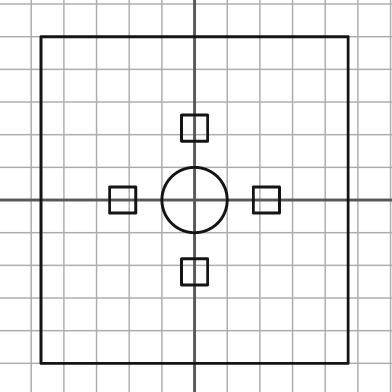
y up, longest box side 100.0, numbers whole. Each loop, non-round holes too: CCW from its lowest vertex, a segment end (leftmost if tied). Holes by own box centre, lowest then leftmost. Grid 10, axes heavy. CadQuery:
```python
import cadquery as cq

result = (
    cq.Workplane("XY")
    .moveTo(-47.0, -50.0)
    .lineTo(47.0, -50.0)
    .lineTo(47.0, 50.0)
    .lineTo(-47.0, 50.0)
    .close()
    .moveTo(-4.0, -26.0)
    .lineTo(4.0, -26.0)
    .lineTo(4.0, -18.0)
    .lineTo(-4.0, -18.0)
    .close()
    .moveTo(-26.0, -4.0)
    .lineTo(-18.0, -4.0)
    .lineTo(-18.0, 4.0)
    .lineTo(-26.0, 4.0)
    .close()
    .moveTo(0.0, 0.0)
    .circle(10.0)
    .moveTo(18.0, -4.0)
    .lineTo(26.0, -4.0)
    .lineTo(26.0, 4.0)
    .lineTo(18.0, 4.0)
    .close()
    .moveTo(-4.0, 18.0)
    .lineTo(4.0, 18.0)
    .lineTo(4.0, 26.0)
    .lineTo(-4.0, 26.0)
    .close()
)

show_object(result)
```